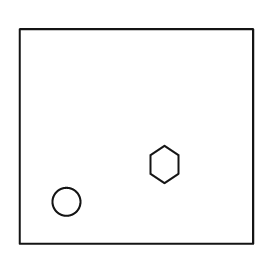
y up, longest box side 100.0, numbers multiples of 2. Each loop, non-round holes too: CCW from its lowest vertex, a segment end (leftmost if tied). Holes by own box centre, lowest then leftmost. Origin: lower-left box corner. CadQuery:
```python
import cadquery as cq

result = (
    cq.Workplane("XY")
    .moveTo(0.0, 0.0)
    .lineTo(100.0, 0.0)
    .lineTo(100.0, 92.0)
    .lineTo(0.0, 92.0)
    .close()
    .moveTo(20.0, 18.0)
    .circle(6.0)
    .moveTo(62.0, 26.0)
    .lineTo(68.0, 30.0)
    .lineTo(68.0, 38.0)
    .lineTo(62.0, 42.0)
    .lineTo(56.0, 38.0)
    .lineTo(56.0, 30.0)
    .close()
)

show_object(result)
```